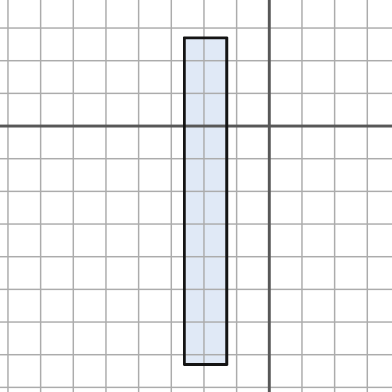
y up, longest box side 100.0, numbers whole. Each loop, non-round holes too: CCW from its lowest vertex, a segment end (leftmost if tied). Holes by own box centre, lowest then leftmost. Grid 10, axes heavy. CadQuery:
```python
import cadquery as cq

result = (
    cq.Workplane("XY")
    .moveTo(-26.0, -73.0)
    .lineTo(-13.0, -73.0)
    .lineTo(-13.0, 27.0)
    .lineTo(-26.0, 27.0)
    .close()
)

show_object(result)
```